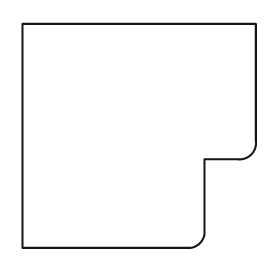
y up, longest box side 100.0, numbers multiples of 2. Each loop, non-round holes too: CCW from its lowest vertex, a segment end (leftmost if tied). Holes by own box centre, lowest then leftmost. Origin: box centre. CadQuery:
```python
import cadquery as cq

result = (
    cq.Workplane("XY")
    .moveTo(-50.0, -48.0)
    .lineTo(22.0, -48.0)
    .threePointArc((26.0, -46.0), (28.0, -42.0))
    .lineTo(28.0, -10.0)
    .lineTo(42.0, -10.0)
    .threePointArc((48.0, -8.0), (50.0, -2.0))
    .lineTo(50.0, 48.0)
    .lineTo(-50.0, 48.0)
    .close()
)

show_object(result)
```